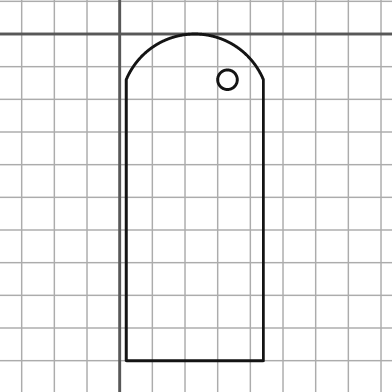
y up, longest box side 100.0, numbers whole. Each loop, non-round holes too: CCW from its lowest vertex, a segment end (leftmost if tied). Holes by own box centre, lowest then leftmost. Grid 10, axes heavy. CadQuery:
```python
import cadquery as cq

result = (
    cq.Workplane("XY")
    .moveTo(2.0, -100.0)
    .lineTo(44.0, -100.0)
    .lineTo(44.0, -14.0)
    .threePointArc((23.0, 0.0), (2.0, -14.0))
    .close()
    .moveTo(33.0, -14.0)
    .circle(3.0)
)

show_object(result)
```